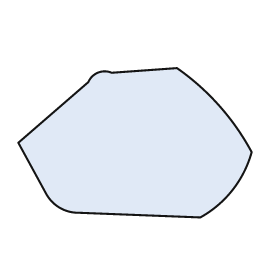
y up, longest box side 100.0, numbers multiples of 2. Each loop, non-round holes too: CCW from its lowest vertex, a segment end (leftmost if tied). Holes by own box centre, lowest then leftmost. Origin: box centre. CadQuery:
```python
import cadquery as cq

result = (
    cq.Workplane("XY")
    .moveTo(28.0, -32.0)
    .threePointArc((42.0, -20.0), (50.0, -4.0))
    .threePointArc((36.0, 16.0), (18.0, 32.0))
    .lineTo(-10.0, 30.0)
    .threePointArc((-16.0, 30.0), (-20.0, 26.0))
    .lineTo(-50.0, 0.0)
    .lineTo(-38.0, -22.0)
    .threePointArc((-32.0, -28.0), (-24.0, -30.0))
    .close()
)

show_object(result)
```